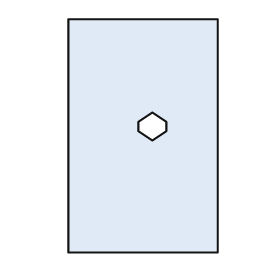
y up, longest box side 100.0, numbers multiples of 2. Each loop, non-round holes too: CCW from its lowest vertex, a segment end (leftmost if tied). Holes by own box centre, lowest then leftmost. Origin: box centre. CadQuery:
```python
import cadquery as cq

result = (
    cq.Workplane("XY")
    .moveTo(-32.0, -50.0)
    .lineTo(32.0, -50.0)
    .lineTo(32.0, 50.0)
    .lineTo(-32.0, 50.0)
    .close()
    .moveTo(4.0, -2.0)
    .lineTo(10.0, 2.0)
    .lineTo(10.0, 6.0)
    .lineTo(4.0, 10.0)
    .lineTo(-2.0, 6.0)
    .lineTo(-2.0, 2.0)
    .close()
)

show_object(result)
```